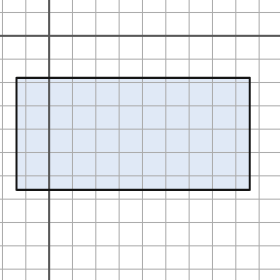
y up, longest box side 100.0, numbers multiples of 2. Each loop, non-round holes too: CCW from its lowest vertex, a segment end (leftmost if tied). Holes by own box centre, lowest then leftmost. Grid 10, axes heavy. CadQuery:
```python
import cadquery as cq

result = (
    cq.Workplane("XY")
    .moveTo(-14.0, -66.0)
    .lineTo(86.0, -66.0)
    .lineTo(86.0, -18.0)
    .lineTo(-14.0, -18.0)
    .close()
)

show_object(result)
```